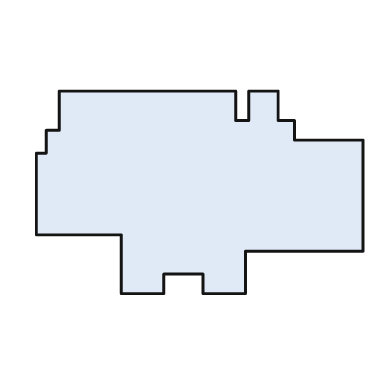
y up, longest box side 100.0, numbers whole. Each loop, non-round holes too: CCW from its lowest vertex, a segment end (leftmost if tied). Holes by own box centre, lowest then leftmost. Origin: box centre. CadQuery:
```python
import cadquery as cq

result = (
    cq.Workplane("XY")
    .moveTo(-24.0, -31.0)
    .lineTo(-11.0, -31.0)
    .lineTo(-11.0, -25.0)
    .lineTo(1.0, -25.0)
    .lineTo(1.0, -31.0)
    .lineTo(14.0, -31.0)
    .lineTo(14.0, -18.0)
    .lineTo(50.0, -18.0)
    .lineTo(50.0, 16.0)
    .lineTo(29.0, 16.0)
    .lineTo(29.0, 22.0)
    .lineTo(24.0, 22.0)
    .lineTo(24.0, 31.0)
    .lineTo(15.0, 31.0)
    .lineTo(15.0, 22.0)
    .lineTo(11.0, 22.0)
    .lineTo(11.0, 31.0)
    .lineTo(-43.0, 31.0)
    .lineTo(-43.0, 19.0)
    .lineTo(-47.0, 19.0)
    .lineTo(-47.0, 12.0)
    .lineTo(-50.0, 12.0)
    .lineTo(-50.0, -13.0)
    .lineTo(-24.0, -13.0)
    .close()
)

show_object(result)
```